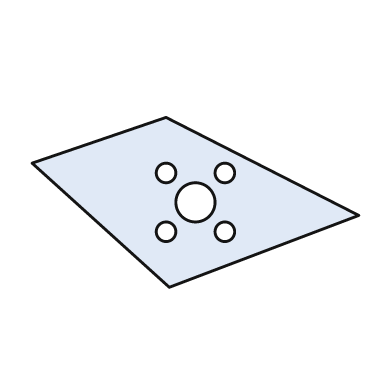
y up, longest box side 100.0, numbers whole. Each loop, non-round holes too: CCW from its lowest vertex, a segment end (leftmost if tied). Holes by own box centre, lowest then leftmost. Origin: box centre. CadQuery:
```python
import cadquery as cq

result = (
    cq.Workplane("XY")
    .moveTo(-8.0, -26.0)
    .lineTo(50.0, -4.0)
    .lineTo(-9.0, 26.0)
    .lineTo(-50.0, 12.0)
    .close()
    .moveTo(-9.0, -9.0)
    .circle(3.0)
    .moveTo(9.0, -9.0)
    .circle(3.0)
    .moveTo(0.0, 0.0)
    .circle(6.0)
    .moveTo(-9.0, 9.0)
    .circle(3.0)
    .moveTo(9.0, 9.0)
    .circle(3.0)
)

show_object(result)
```